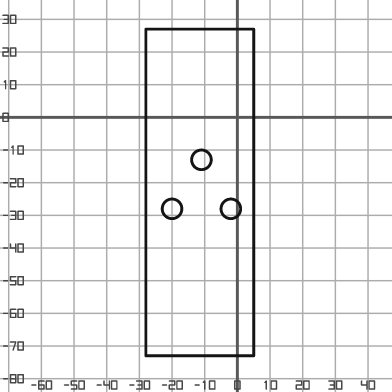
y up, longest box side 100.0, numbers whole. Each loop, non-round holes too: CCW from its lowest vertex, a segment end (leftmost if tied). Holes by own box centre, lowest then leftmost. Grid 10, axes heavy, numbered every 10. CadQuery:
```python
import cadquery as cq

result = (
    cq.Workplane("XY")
    .moveTo(-28.0, -73.0)
    .lineTo(5.0, -73.0)
    .lineTo(5.0, 27.0)
    .lineTo(-28.0, 27.0)
    .close()
    .moveTo(-20.0, -28.0)
    .circle(3.0)
    .moveTo(-2.0, -28.0)
    .circle(3.0)
    .moveTo(-11.0, -13.0)
    .circle(3.0)
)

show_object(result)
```